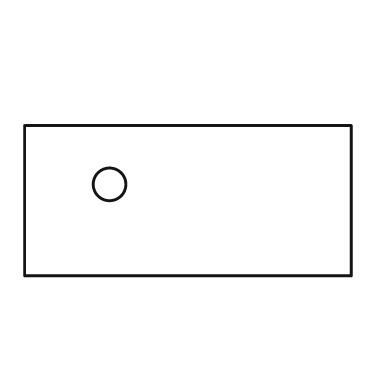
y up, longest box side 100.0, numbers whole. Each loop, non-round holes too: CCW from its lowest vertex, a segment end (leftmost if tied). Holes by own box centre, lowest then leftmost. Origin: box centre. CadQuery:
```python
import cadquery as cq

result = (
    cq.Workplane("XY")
    .moveTo(-50.0, -23.0)
    .lineTo(50.0, -23.0)
    .lineTo(50.0, 23.0)
    .lineTo(-50.0, 23.0)
    .close()
    .moveTo(-24.0, 5.0)
    .circle(5.0)
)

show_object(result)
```